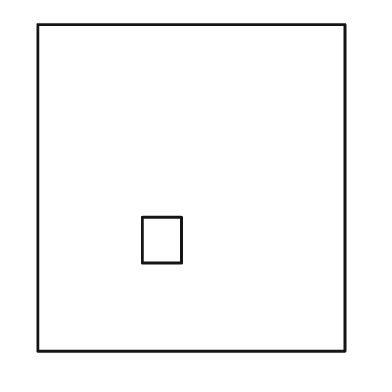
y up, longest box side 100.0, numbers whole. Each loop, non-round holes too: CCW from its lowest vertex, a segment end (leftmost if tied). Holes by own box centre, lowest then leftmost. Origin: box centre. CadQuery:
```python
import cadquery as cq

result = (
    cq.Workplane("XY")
    .moveTo(-47.0, -50.0)
    .lineTo(47.0, -50.0)
    .lineTo(47.0, 50.0)
    .lineTo(-47.0, 50.0)
    .close()
    .moveTo(-15.0, -23.0)
    .lineTo(-3.0, -23.0)
    .lineTo(-3.0, -9.0)
    .lineTo(-15.0, -9.0)
    .close()
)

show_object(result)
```